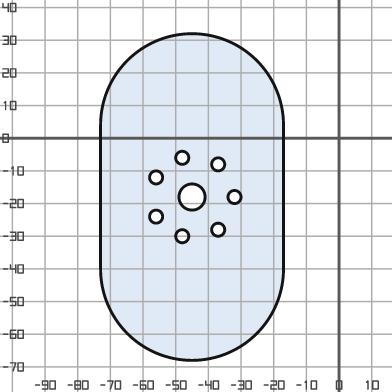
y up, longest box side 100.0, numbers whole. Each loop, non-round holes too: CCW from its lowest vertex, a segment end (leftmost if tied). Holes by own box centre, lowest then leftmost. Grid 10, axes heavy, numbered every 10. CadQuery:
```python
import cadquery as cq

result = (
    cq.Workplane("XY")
    .moveTo(-73.0, -40.0)
    .threePointArc((-45.0, -68.0), (-17.0, -40.0))
    .lineTo(-17.0, 4.0)
    .threePointArc((-45.0, 32.0), (-73.0, 4.0))
    .close()
    .moveTo(-48.0, -30.0)
    .circle(2.0)
    .moveTo(-37.0, -28.0)
    .circle(2.0)
    .moveTo(-56.0, -24.0)
    .circle(2.0)
    .moveTo(-45.0, -18.0)
    .circle(4.0)
    .moveTo(-32.0, -18.0)
    .circle(2.0)
    .moveTo(-56.0, -12.0)
    .circle(2.0)
    .moveTo(-37.0, -8.0)
    .circle(2.0)
    .moveTo(-48.0, -6.0)
    .circle(2.0)
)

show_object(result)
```